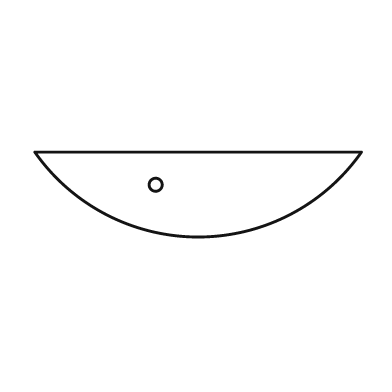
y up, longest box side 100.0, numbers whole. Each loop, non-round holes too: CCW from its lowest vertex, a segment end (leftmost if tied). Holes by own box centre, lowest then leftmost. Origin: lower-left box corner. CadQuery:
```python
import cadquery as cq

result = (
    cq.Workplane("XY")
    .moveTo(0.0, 26.0)
    .threePointArc((50.0, 0.0), (100.0, 26.0))
    .close()
    .moveTo(37.0, 16.0)
    .circle(2.0)
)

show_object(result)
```